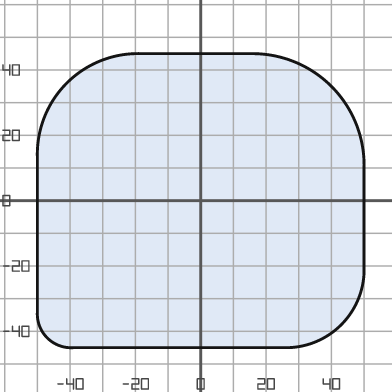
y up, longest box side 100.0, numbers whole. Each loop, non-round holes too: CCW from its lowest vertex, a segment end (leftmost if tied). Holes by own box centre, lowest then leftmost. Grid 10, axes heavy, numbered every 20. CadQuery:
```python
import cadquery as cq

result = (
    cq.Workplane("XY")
    .moveTo(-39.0, -45.0)
    .lineTo(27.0, -45.0)
    .threePointArc((43.0, -38.0), (50.0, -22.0))
    .lineTo(50.0, 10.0)
    .threePointArc((40.0, 35.0), (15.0, 45.0))
    .lineTo(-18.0, 45.0)
    .threePointArc((-41.0, 36.0), (-50.0, 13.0))
    .lineTo(-50.0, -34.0)
    .threePointArc((-47.0, -42.0), (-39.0, -45.0))
    .close()
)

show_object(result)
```